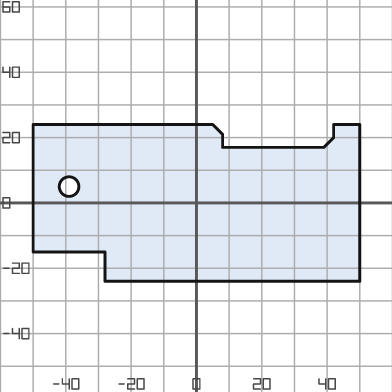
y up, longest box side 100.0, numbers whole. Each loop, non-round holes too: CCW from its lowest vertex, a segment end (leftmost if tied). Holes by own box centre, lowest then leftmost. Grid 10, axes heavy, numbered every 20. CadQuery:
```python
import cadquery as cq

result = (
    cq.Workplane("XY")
    .moveTo(-28.0, -24.0)
    .lineTo(50.0, -24.0)
    .lineTo(50.0, 24.0)
    .lineTo(42.0, 24.0)
    .lineTo(42.0, 20.0)
    .lineTo(39.0, 17.0)
    .lineTo(8.0, 17.0)
    .lineTo(8.0, 21.0)
    .lineTo(5.0, 24.0)
    .lineTo(-50.0, 24.0)
    .lineTo(-50.0, -15.0)
    .lineTo(-28.0, -15.0)
    .close()
    .moveTo(-39.0, 5.0)
    .circle(3.0)
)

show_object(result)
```